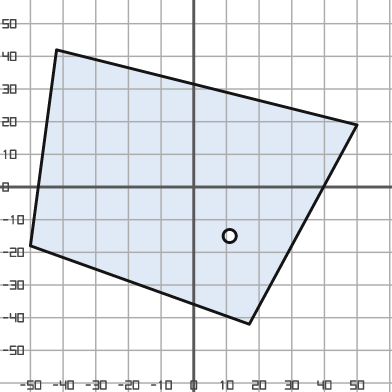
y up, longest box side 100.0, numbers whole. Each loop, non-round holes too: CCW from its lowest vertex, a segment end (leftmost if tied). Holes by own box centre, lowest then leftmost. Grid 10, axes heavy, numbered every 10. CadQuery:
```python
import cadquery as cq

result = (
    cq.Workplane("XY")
    .moveTo(17.0, -42.0)
    .lineTo(50.0, 19.0)
    .lineTo(-42.0, 42.0)
    .lineTo(-50.0, -18.0)
    .close()
    .moveTo(11.0, -15.0)
    .circle(2.0)
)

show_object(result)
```